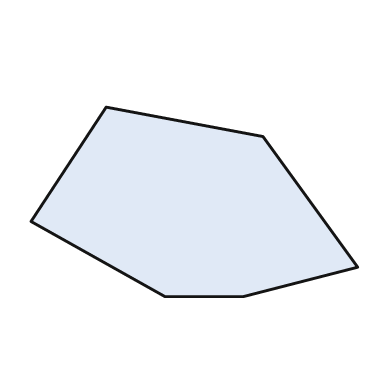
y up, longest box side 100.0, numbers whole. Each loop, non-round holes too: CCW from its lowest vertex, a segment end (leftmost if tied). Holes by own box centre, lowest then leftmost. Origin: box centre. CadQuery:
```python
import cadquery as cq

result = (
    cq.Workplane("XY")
    .moveTo(-9.0, -29.0)
    .lineTo(15.0, -29.0)
    .lineTo(50.0, -20.0)
    .lineTo(21.0, 20.0)
    .lineTo(-27.0, 29.0)
    .lineTo(-50.0, -6.0)
    .close()
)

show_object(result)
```